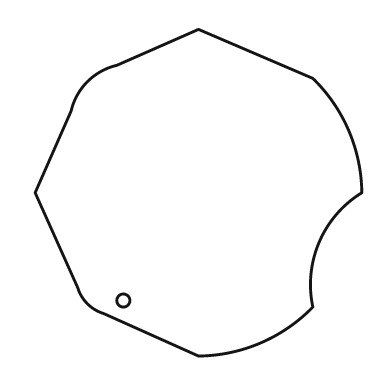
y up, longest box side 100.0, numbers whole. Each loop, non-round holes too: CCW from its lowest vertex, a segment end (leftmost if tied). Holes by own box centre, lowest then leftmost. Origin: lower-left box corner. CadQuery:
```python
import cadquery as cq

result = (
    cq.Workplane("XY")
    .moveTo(50.0, 0.0)
    .threePointArc((69.0, 4.0), (85.0, 15.0))
    .threePointArc((87.0, 35.0), (100.0, 50.0))
    .threePointArc((96.0, 69.0), (85.0, 85.0))
    .lineTo(50.0, 100.0)
    .lineTo(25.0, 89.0)
    .threePointArc((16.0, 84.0), (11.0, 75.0))
    .lineTo(0.0, 50.0)
    .lineTo(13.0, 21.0)
    .threePointArc((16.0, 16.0), (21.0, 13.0))
    .close()
    .moveTo(27.0, 17.0)
    .circle(2.0)
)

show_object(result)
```